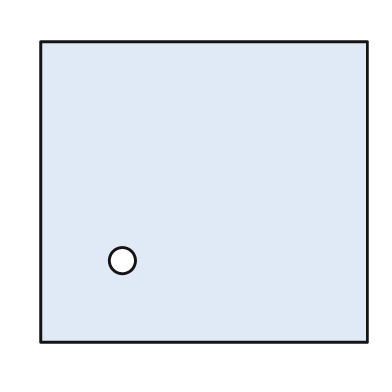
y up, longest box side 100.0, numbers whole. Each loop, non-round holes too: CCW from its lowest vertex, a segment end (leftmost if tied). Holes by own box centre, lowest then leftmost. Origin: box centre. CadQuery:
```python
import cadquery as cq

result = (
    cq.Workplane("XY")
    .moveTo(-50.0, -46.0)
    .lineTo(50.0, -46.0)
    .lineTo(50.0, 46.0)
    .lineTo(-50.0, 46.0)
    .close()
    .moveTo(-25.0, -21.0)
    .circle(4.0)
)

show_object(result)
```